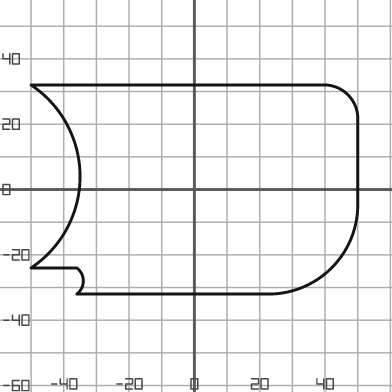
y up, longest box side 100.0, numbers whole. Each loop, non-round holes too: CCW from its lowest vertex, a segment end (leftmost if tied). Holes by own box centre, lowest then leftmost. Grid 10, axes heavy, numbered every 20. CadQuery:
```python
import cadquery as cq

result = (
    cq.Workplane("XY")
    .moveTo(-36.0, -32.0)
    .lineTo(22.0, -32.0)
    .threePointArc((42.0, -24.0), (50.0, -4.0))
    .lineTo(50.0, 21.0)
    .threePointArc((47.0, 29.0), (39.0, 32.0))
    .lineTo(-50.0, 32.0)
    .threePointArc((-35.0, 4.0), (-50.0, -24.0))
    .lineTo(-36.0, -24.0)
    .threePointArc((-34.0, -28.0), (-36.0, -32.0))
    .close()
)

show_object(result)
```